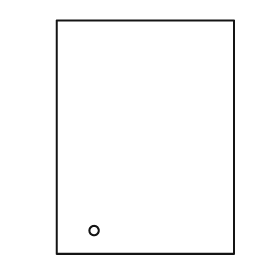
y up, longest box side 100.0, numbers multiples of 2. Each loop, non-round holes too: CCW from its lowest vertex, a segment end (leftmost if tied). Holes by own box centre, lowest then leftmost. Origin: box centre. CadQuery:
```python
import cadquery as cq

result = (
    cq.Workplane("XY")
    .moveTo(-38.0, -50.0)
    .lineTo(38.0, -50.0)
    .lineTo(38.0, 50.0)
    .lineTo(-38.0, 50.0)
    .close()
    .moveTo(-22.0, -40.0)
    .circle(2.0)
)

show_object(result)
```